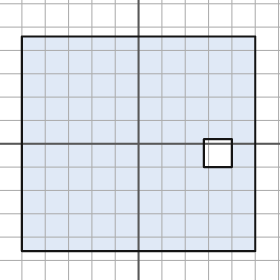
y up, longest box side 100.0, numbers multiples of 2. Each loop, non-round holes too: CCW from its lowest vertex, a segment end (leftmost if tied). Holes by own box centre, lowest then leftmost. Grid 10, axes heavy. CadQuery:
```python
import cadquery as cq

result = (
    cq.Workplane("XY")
    .moveTo(-50.0, -46.0)
    .lineTo(50.0, -46.0)
    .lineTo(50.0, 46.0)
    .lineTo(-50.0, 46.0)
    .close()
    .moveTo(28.0, -10.0)
    .lineTo(40.0, -10.0)
    .lineTo(40.0, 2.0)
    .lineTo(28.0, 2.0)
    .close()
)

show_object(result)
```